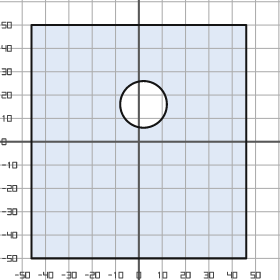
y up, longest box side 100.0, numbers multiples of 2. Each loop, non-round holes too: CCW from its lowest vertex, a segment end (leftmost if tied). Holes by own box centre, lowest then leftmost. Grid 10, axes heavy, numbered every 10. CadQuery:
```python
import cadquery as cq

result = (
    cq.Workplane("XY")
    .moveTo(-46.0, -50.0)
    .lineTo(46.0, -50.0)
    .lineTo(46.0, 50.0)
    .lineTo(-46.0, 50.0)
    .close()
    .moveTo(2.0, 16.0)
    .circle(10.0)
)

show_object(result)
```